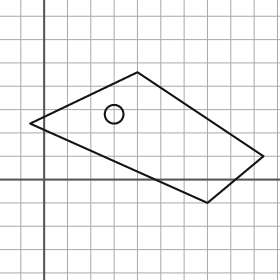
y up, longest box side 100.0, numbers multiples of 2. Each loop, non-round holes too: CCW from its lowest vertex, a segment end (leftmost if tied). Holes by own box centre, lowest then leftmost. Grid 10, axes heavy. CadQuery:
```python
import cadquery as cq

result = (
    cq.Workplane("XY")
    .moveTo(70.0, -10.0)
    .lineTo(94.0, 10.0)
    .lineTo(40.0, 46.0)
    .lineTo(-6.0, 24.0)
    .close()
    .moveTo(30.0, 28.0)
    .circle(4.0)
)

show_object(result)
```